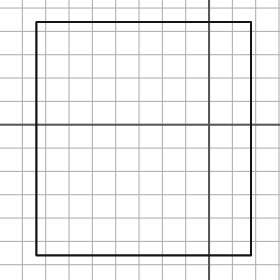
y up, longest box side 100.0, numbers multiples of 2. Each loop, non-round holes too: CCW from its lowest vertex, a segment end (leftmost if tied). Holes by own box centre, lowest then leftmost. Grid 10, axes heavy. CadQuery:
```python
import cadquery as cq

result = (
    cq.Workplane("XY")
    .moveTo(-74.0, -56.0)
    .lineTo(18.0, -56.0)
    .lineTo(18.0, 44.0)
    .lineTo(-74.0, 44.0)
    .close()
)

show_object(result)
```